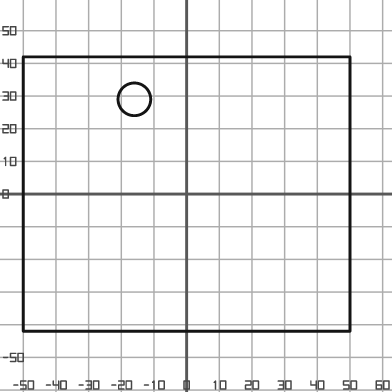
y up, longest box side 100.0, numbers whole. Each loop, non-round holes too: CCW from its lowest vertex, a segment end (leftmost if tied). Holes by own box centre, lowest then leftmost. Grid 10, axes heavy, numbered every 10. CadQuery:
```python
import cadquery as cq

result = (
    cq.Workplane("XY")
    .moveTo(-50.0, -42.0)
    .lineTo(50.0, -42.0)
    .lineTo(50.0, 42.0)
    .lineTo(-50.0, 42.0)
    .close()
    .moveTo(-16.0, 29.0)
    .circle(5.0)
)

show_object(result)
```